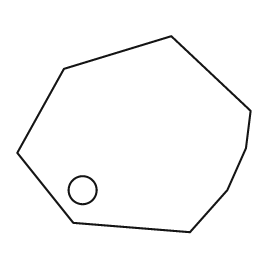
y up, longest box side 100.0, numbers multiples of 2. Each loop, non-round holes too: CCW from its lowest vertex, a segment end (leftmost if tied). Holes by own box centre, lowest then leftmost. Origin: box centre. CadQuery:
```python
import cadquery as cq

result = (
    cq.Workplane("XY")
    .moveTo(24.0, -42.0)
    .lineTo(40.0, -24.0)
    .lineTo(48.0, -6.0)
    .lineTo(50.0, 10.0)
    .lineTo(16.0, 42.0)
    .lineTo(-30.0, 28.0)
    .lineTo(-50.0, -8.0)
    .lineTo(-26.0, -38.0)
    .close()
    .moveTo(-22.0, -24.0)
    .circle(6.0)
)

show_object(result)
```